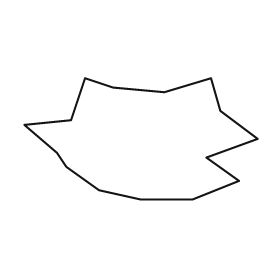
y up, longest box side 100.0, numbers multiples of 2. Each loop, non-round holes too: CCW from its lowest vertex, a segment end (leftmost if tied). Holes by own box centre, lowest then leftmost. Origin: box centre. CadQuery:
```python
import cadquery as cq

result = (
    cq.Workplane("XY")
    .moveTo(0.0, -26.0)
    .lineTo(22.0, -26.0)
    .lineTo(42.0, -18.0)
    .lineTo(28.0, -8.0)
    .lineTo(50.0, 0.0)
    .lineTo(34.0, 12.0)
    .lineTo(30.0, 26.0)
    .lineTo(10.0, 20.0)
    .lineTo(-12.0, 22.0)
    .lineTo(-24.0, 26.0)
    .lineTo(-30.0, 8.0)
    .lineTo(-50.0, 6.0)
    .lineTo(-36.0, -6.0)
    .lineTo(-32.0, -12.0)
    .lineTo(-18.0, -22.0)
    .close()
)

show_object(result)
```